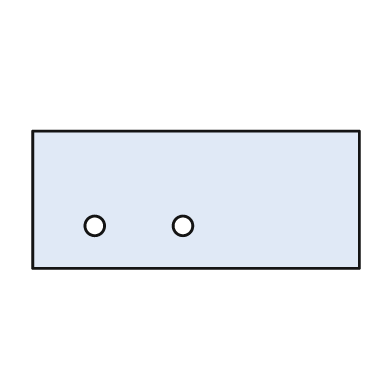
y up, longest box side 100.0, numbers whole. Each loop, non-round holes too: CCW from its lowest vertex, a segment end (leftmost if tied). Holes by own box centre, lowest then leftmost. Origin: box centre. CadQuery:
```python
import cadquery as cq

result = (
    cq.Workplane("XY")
    .moveTo(-50.0, -21.0)
    .lineTo(50.0, -21.0)
    .lineTo(50.0, 21.0)
    .lineTo(-50.0, 21.0)
    .close()
    .moveTo(-31.0, -8.0)
    .circle(3.0)
    .moveTo(-4.0, -8.0)
    .circle(3.0)
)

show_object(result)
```